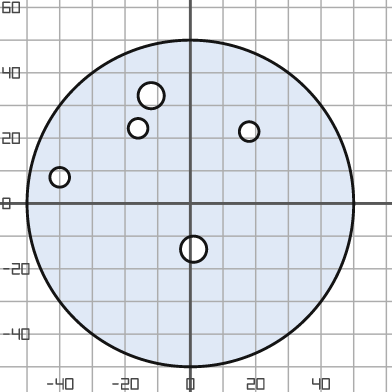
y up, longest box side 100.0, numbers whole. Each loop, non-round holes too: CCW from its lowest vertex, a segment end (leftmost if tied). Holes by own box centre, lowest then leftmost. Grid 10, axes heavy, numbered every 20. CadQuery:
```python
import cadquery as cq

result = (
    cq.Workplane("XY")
    .moveTo(0.0, 0.0)
    .circle(50.0)
    .moveTo(1.0, -14.0)
    .circle(4.0)
    .moveTo(-40.0, 8.0)
    .circle(3.0)
    .moveTo(18.0, 22.0)
    .circle(3.0)
    .moveTo(-16.0, 23.0)
    .circle(3.0)
    .moveTo(-12.0, 33.0)
    .circle(4.0)
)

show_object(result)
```